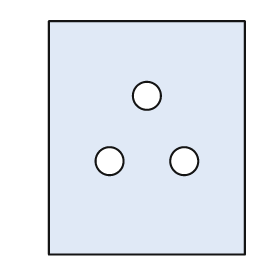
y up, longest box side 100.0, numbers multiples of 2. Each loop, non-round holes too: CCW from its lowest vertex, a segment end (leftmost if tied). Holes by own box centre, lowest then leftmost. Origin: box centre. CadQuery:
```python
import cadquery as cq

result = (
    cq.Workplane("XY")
    .moveTo(-42.0, -50.0)
    .lineTo(42.0, -50.0)
    .lineTo(42.0, 50.0)
    .lineTo(-42.0, 50.0)
    .close()
    .moveTo(-16.0, -10.0)
    .circle(6.0)
    .moveTo(16.0, -10.0)
    .circle(6.0)
    .moveTo(0.0, 18.0)
    .circle(6.0)
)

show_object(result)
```